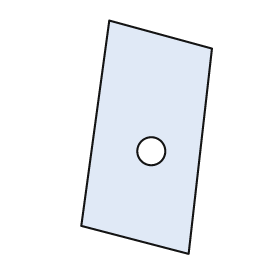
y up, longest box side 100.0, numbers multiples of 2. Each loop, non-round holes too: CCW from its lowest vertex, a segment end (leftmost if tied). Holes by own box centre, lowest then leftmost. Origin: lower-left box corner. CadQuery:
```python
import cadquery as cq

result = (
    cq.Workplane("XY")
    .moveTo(46.0, 0.0)
    .lineTo(56.0, 88.0)
    .lineTo(12.0, 100.0)
    .lineTo(0.0, 12.0)
    .close()
    .moveTo(30.0, 44.0)
    .circle(6.0)
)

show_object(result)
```